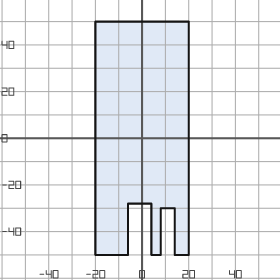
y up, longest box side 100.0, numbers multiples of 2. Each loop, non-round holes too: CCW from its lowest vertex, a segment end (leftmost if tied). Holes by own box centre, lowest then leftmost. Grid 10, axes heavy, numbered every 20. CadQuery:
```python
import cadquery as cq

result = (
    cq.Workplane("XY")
    .moveTo(-20.0, -50.0)
    .lineTo(-6.0, -50.0)
    .lineTo(-6.0, -28.0)
    .lineTo(4.0, -28.0)
    .lineTo(4.0, -50.0)
    .lineTo(8.0, -50.0)
    .lineTo(8.0, -30.0)
    .lineTo(14.0, -30.0)
    .lineTo(14.0, -50.0)
    .lineTo(20.0, -50.0)
    .lineTo(20.0, 50.0)
    .lineTo(-20.0, 50.0)
    .close()
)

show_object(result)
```